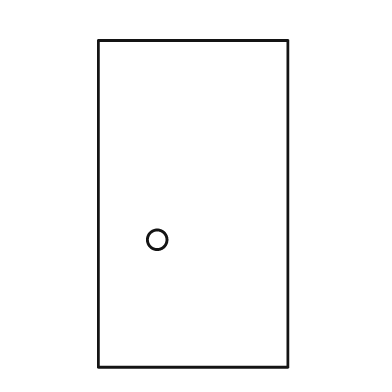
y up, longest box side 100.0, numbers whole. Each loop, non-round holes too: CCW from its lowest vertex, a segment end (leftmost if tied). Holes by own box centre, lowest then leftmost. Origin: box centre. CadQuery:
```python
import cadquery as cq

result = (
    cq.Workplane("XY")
    .moveTo(-29.0, -50.0)
    .lineTo(29.0, -50.0)
    .lineTo(29.0, 50.0)
    .lineTo(-29.0, 50.0)
    .close()
    .moveTo(-11.0, -11.0)
    .circle(3.0)
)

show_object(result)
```